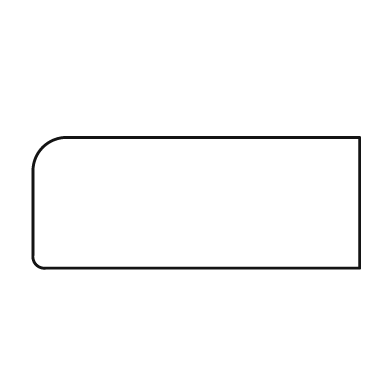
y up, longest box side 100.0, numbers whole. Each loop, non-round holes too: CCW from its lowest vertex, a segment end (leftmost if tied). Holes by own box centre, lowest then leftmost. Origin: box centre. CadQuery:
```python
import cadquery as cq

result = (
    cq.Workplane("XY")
    .moveTo(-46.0, -20.0)
    .lineTo(50.0, -20.0)
    .lineTo(50.0, 20.0)
    .lineTo(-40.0, 20.0)
    .threePointArc((-47.0, 17.0), (-50.0, 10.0))
    .lineTo(-50.0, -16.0)
    .threePointArc((-49.0, -19.0), (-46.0, -20.0))
    .close()
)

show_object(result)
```